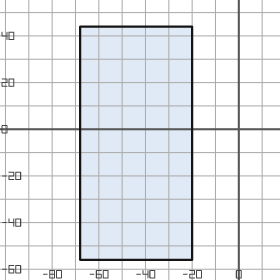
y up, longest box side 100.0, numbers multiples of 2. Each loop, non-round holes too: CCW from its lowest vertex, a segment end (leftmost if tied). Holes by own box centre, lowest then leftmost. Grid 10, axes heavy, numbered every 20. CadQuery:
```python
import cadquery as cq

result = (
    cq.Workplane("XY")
    .moveTo(-68.0, -56.0)
    .lineTo(-20.0, -56.0)
    .lineTo(-20.0, 44.0)
    .lineTo(-68.0, 44.0)
    .close()
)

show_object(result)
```